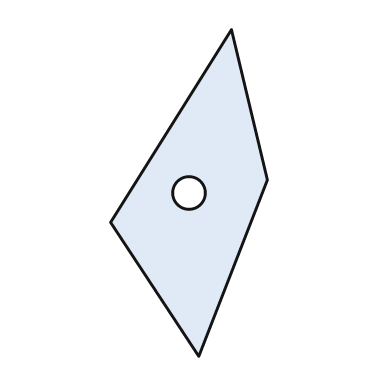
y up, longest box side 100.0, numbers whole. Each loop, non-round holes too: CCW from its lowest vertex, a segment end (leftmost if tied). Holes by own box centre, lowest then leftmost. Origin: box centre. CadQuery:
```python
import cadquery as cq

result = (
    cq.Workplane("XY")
    .moveTo(3.0, -50.0)
    .lineTo(24.0, 4.0)
    .lineTo(13.0, 50.0)
    .lineTo(-24.0, -9.0)
    .close()
    .moveTo(0.0, 0.0)
    .circle(5.0)
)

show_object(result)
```